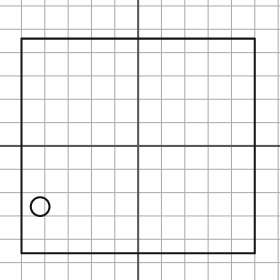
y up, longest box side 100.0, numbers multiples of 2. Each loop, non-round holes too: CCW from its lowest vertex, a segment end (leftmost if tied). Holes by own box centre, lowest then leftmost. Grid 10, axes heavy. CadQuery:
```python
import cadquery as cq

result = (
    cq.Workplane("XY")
    .moveTo(-50.0, -46.0)
    .lineTo(50.0, -46.0)
    .lineTo(50.0, 46.0)
    .lineTo(-50.0, 46.0)
    .close()
    .moveTo(-42.0, -26.0)
    .circle(4.0)
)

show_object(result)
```